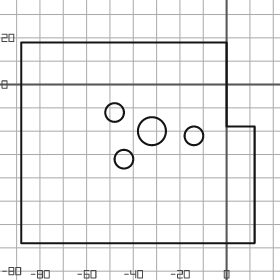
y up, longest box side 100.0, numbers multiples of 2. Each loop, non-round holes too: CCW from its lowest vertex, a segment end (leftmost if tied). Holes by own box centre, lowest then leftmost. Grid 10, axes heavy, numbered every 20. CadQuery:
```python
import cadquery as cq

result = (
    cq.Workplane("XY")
    .moveTo(-88.0, -68.0)
    .lineTo(12.0, -68.0)
    .lineTo(12.0, -18.0)
    .lineTo(0.0, -18.0)
    .lineTo(0.0, 18.0)
    .lineTo(-88.0, 18.0)
    .close()
    .moveTo(-44.0, -32.0)
    .circle(4.0)
    .moveTo(-14.0, -22.0)
    .circle(4.0)
    .moveTo(-32.0, -20.0)
    .circle(6.0)
    .moveTo(-48.0, -12.0)
    .circle(4.0)
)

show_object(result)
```